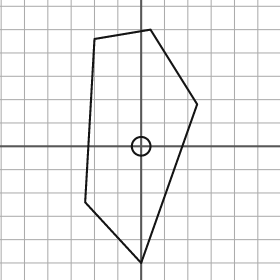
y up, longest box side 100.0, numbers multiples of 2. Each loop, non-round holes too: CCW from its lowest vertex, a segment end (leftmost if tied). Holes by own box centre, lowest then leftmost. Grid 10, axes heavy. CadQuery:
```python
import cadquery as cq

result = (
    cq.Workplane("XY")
    .moveTo(0.0, -50.0)
    .lineTo(24.0, 18.0)
    .lineTo(4.0, 50.0)
    .lineTo(-20.0, 46.0)
    .lineTo(-24.0, -24.0)
    .close()
    .moveTo(0.0, 0.0)
    .circle(4.0)
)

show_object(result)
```